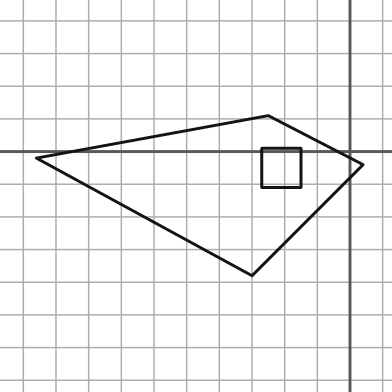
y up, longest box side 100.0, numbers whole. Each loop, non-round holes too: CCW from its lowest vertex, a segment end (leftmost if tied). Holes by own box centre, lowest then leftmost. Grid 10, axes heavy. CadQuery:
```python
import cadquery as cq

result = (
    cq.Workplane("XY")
    .moveTo(-30.0, -38.0)
    .lineTo(4.0, -4.0)
    .lineTo(-25.0, 11.0)
    .lineTo(-96.0, -2.0)
    .close()
    .moveTo(-27.0, -11.0)
    .lineTo(-15.0, -11.0)
    .lineTo(-15.0, 1.0)
    .lineTo(-27.0, 1.0)
    .close()
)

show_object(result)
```